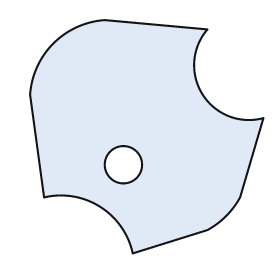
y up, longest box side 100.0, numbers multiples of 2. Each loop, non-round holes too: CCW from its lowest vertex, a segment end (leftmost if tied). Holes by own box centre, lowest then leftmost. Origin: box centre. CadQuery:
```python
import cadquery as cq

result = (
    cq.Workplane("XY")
    .moveTo(-6.0, -50.0)
    .lineTo(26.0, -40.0)
    .threePointArc((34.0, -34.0), (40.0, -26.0))
    .lineTo(50.0, 8.0)
    .threePointArc((24.0, 18.0), (26.0, 46.0))
    .lineTo(-18.0, 50.0)
    .threePointArc((-40.0, 40.0), (-50.0, 18.0))
    .lineTo(-44.0, -26.0)
    .threePointArc((-20.0, -30.0), (-6.0, -50.0))
    .close()
    .moveTo(-10.0, -12.0)
    .circle(8.0)
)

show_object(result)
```